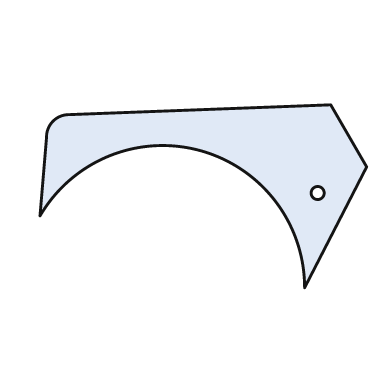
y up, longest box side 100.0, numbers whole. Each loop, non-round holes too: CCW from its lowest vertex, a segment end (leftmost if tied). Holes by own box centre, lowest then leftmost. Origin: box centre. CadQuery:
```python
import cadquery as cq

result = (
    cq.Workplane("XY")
    .moveTo(31.0, -28.0)
    .lineTo(50.0, 9.0)
    .lineTo(39.0, 28.0)
    .lineTo(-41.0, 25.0)
    .threePointArc((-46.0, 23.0), (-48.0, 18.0))
    .lineTo(-50.0, -6.0)
    .threePointArc((-1.0, 14.0), (31.0, -28.0))
    .close()
    .moveTo(35.0, 1.0)
    .circle(2.0)
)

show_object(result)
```